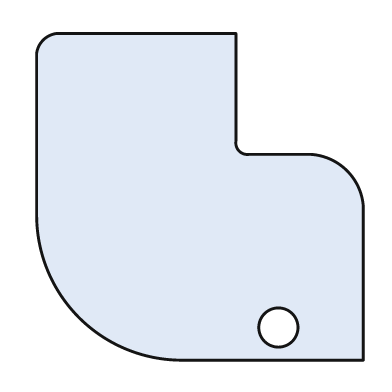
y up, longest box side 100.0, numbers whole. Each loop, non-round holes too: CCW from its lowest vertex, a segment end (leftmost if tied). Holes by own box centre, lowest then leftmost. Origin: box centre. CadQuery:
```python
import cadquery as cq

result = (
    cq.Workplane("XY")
    .moveTo(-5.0, -50.0)
    .lineTo(50.0, -50.0)
    .lineTo(50.0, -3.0)
    .threePointArc((45.0, 8.0), (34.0, 13.0))
    .lineTo(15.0, 13.0)
    .threePointArc((12.0, 14.0), (11.0, 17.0))
    .lineTo(11.0, 50.0)
    .lineTo(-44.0, 50.0)
    .threePointArc((-48.0, 48.0), (-50.0, 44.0))
    .lineTo(-50.0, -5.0)
    .threePointArc((-37.0, -37.0), (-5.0, -50.0))
    .close()
    .moveTo(24.0, -40.0)
    .circle(6.0)
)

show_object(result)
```